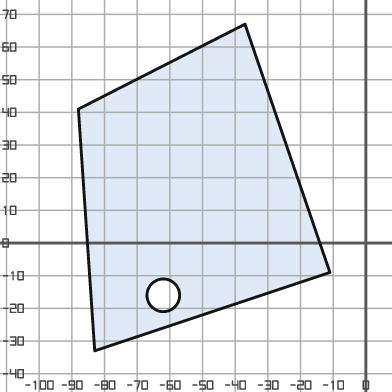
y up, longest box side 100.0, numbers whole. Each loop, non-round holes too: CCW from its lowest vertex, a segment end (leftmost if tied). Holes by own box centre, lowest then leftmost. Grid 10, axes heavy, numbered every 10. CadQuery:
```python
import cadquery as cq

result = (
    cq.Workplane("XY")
    .moveTo(-83.0, -33.0)
    .lineTo(-11.0, -9.0)
    .lineTo(-37.0, 67.0)
    .lineTo(-88.0, 41.0)
    .close()
    .moveTo(-62.0, -16.0)
    .circle(5.0)
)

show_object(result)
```